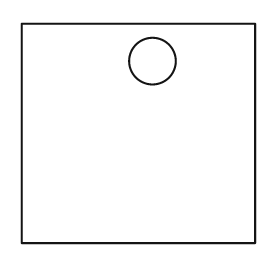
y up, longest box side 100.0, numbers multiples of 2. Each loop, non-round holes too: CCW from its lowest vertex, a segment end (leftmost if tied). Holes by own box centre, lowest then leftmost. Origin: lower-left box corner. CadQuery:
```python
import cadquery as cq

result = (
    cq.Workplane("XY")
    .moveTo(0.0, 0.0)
    .lineTo(100.0, 0.0)
    .lineTo(100.0, 94.0)
    .lineTo(0.0, 94.0)
    .close()
    .moveTo(56.0, 78.0)
    .circle(10.0)
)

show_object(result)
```